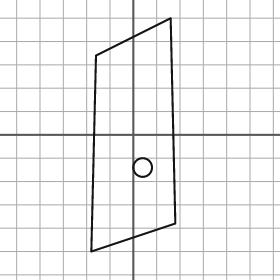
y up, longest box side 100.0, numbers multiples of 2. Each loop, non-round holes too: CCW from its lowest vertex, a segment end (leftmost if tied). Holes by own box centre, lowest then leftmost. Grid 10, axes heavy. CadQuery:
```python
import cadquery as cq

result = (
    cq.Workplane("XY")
    .moveTo(-18.0, -50.0)
    .lineTo(18.0, -38.0)
    .lineTo(16.0, 50.0)
    .lineTo(-16.0, 34.0)
    .close()
    .moveTo(4.0, -14.0)
    .circle(4.0)
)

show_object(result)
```